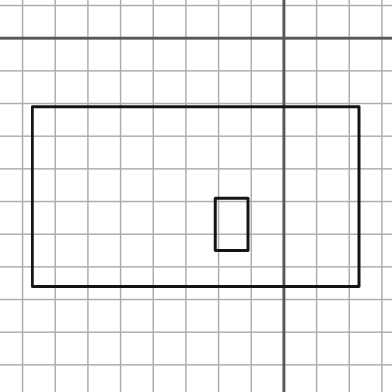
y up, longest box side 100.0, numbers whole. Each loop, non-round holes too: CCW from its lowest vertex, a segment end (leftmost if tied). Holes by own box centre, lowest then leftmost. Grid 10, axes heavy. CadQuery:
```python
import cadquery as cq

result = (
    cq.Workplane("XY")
    .moveTo(-77.0, -76.0)
    .lineTo(23.0, -76.0)
    .lineTo(23.0, -21.0)
    .lineTo(-77.0, -21.0)
    .close()
    .moveTo(-21.0, -65.0)
    .lineTo(-11.0, -65.0)
    .lineTo(-11.0, -49.0)
    .lineTo(-21.0, -49.0)
    .close()
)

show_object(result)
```